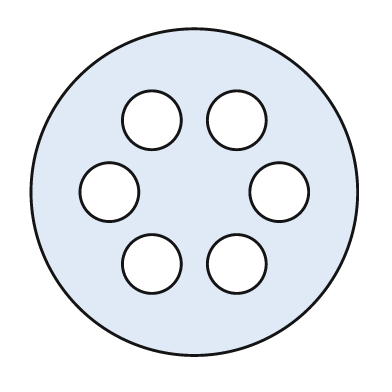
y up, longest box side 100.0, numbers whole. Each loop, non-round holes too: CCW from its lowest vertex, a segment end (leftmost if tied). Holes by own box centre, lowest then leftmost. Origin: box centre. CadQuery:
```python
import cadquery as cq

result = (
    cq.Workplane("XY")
    .moveTo(0.0, 0.0)
    .circle(50.0)
    .moveTo(-13.0, -22.0)
    .circle(9.0)
    .moveTo(13.0, -22.0)
    .circle(9.0)
    .moveTo(-26.0, 0.0)
    .circle(9.0)
    .moveTo(26.0, 0.0)
    .circle(9.0)
    .moveTo(-13.0, 22.0)
    .circle(9.0)
    .moveTo(13.0, 22.0)
    .circle(9.0)
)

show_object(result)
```